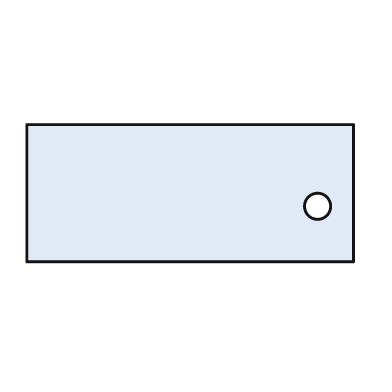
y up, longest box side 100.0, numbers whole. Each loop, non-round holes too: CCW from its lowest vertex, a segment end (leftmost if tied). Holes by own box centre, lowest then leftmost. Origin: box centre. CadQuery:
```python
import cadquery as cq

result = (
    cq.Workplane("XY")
    .moveTo(-50.0, -21.0)
    .lineTo(50.0, -21.0)
    .lineTo(50.0, 21.0)
    .lineTo(-50.0, 21.0)
    .close()
    .moveTo(39.0, -4.0)
    .circle(4.0)
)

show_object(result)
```